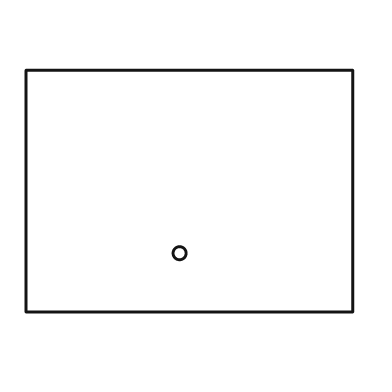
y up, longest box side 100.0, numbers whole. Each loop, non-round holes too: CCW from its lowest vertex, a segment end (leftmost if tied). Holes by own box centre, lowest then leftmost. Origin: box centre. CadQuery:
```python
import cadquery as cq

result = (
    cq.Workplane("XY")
    .moveTo(-50.0, -37.0)
    .lineTo(50.0, -37.0)
    .lineTo(50.0, 37.0)
    .lineTo(-50.0, 37.0)
    .close()
    .moveTo(-3.0, -19.0)
    .circle(2.0)
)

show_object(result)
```